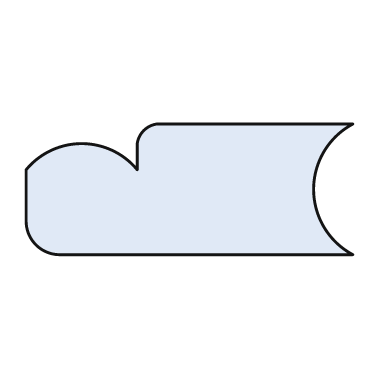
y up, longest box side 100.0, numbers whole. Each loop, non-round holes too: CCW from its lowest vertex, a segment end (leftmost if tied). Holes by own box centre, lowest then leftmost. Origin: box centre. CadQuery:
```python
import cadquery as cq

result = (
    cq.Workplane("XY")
    .moveTo(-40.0, -20.0)
    .lineTo(50.0, -20.0)
    .threePointArc((38.0, 0.0), (50.0, 20.0))
    .lineTo(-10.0, 20.0)
    .threePointArc((-14.0, 18.0), (-16.0, 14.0))
    .lineTo(-16.0, 6.0)
    .threePointArc((-33.0, 14.0), (-50.0, 6.0))
    .lineTo(-50.0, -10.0)
    .threePointArc((-47.0, -17.0), (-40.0, -20.0))
    .close()
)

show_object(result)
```